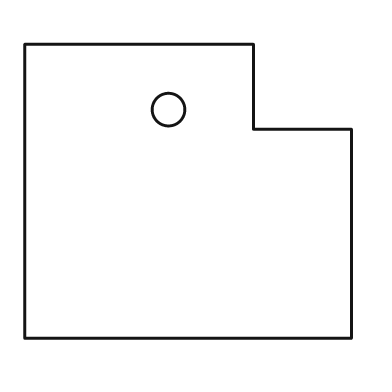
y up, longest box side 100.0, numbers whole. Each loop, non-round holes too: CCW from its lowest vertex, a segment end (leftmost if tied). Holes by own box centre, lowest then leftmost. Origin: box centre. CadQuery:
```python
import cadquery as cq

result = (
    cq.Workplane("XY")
    .moveTo(-50.0, -45.0)
    .lineTo(50.0, -45.0)
    .lineTo(50.0, 19.0)
    .lineTo(20.0, 19.0)
    .lineTo(20.0, 45.0)
    .lineTo(-50.0, 45.0)
    .close()
    .moveTo(-6.0, 25.0)
    .circle(5.0)
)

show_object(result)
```